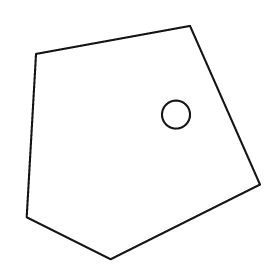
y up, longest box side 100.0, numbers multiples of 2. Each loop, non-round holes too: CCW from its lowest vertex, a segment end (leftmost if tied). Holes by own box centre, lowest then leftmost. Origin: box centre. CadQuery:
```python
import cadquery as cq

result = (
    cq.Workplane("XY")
    .moveTo(-14.0, -50.0)
    .lineTo(50.0, -18.0)
    .lineTo(20.0, 50.0)
    .lineTo(-46.0, 38.0)
    .lineTo(-50.0, -32.0)
    .close()
    .moveTo(14.0, 12.0)
    .circle(6.0)
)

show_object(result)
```